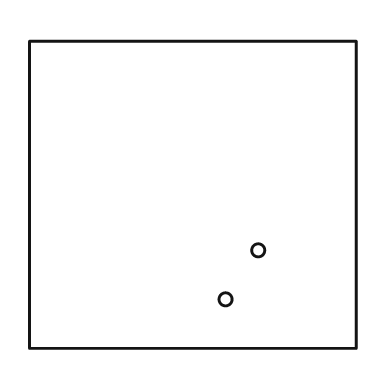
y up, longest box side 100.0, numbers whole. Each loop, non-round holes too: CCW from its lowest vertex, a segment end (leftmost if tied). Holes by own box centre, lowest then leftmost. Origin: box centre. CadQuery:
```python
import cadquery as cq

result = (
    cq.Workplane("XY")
    .moveTo(-50.0, -47.0)
    .lineTo(50.0, -47.0)
    .lineTo(50.0, 47.0)
    .lineTo(-50.0, 47.0)
    .close()
    .moveTo(10.0, -32.0)
    .circle(2.0)
    .moveTo(20.0, -17.0)
    .circle(2.0)
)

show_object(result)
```